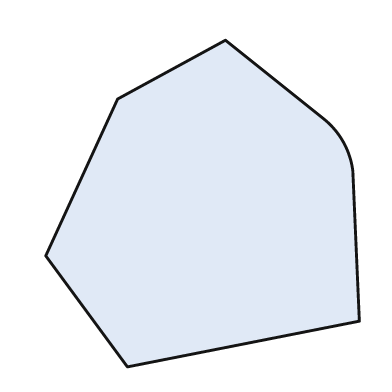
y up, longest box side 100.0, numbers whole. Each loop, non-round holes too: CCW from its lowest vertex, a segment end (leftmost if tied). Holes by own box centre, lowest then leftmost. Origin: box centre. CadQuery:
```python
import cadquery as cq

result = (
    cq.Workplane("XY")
    .moveTo(-23.0, -50.0)
    .lineTo(48.0, -36.0)
    .lineTo(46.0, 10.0)
    .threePointArc((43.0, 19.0), (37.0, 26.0))
    .lineTo(7.0, 50.0)
    .lineTo(-26.0, 32.0)
    .lineTo(-48.0, -16.0)
    .close()
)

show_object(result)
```